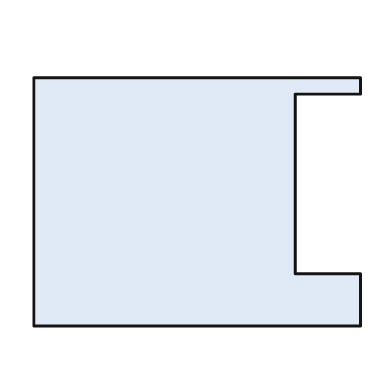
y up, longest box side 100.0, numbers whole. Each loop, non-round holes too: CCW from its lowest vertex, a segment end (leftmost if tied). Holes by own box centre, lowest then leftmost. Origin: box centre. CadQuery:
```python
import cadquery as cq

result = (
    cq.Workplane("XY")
    .moveTo(-50.0, -38.0)
    .lineTo(50.0, -38.0)
    .lineTo(50.0, -22.0)
    .lineTo(30.0, -22.0)
    .lineTo(30.0, 33.0)
    .lineTo(50.0, 33.0)
    .lineTo(50.0, 38.0)
    .lineTo(-50.0, 38.0)
    .close()
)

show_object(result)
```